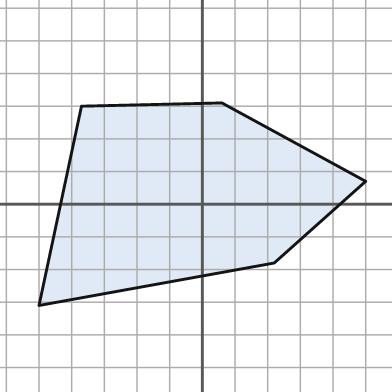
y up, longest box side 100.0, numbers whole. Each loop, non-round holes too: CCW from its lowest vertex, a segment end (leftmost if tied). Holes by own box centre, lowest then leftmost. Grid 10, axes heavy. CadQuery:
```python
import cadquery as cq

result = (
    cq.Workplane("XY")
    .moveTo(-50.0, -31.0)
    .lineTo(22.0, -18.0)
    .lineTo(50.0, 7.0)
    .lineTo(6.0, 31.0)
    .lineTo(-37.0, 30.0)
    .close()
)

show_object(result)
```